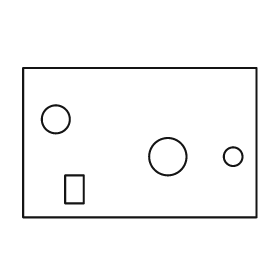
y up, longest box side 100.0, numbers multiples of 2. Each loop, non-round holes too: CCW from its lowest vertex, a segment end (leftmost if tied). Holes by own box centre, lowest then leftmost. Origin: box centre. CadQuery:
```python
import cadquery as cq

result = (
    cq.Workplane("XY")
    .moveTo(-50.0, -32.0)
    .lineTo(50.0, -32.0)
    .lineTo(50.0, 32.0)
    .lineTo(-50.0, 32.0)
    .close()
    .moveTo(-32.0, -26.0)
    .lineTo(-24.0, -26.0)
    .lineTo(-24.0, -14.0)
    .lineTo(-32.0, -14.0)
    .close()
    .moveTo(12.0, -6.0)
    .circle(8.0)
    .moveTo(40.0, -6.0)
    .circle(4.0)
    .moveTo(-36.0, 10.0)
    .circle(6.0)
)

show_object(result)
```